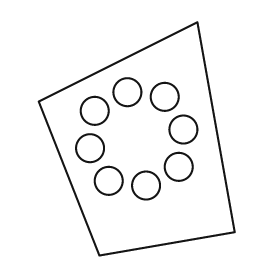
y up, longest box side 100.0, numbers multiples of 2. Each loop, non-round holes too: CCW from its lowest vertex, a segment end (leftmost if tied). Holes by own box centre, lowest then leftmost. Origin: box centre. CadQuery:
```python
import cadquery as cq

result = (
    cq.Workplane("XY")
    .moveTo(-16.0, -50.0)
    .lineTo(42.0, -40.0)
    .lineTo(26.0, 50.0)
    .lineTo(-42.0, 16.0)
    .close()
    .moveTo(4.0, -20.0)
    .circle(6.0)
    .moveTo(-12.0, -18.0)
    .circle(6.0)
    .moveTo(18.0, -12.0)
    .circle(6.0)
    .moveTo(-20.0, -4.0)
    .circle(6.0)
    .moveTo(20.0, 4.0)
    .circle(6.0)
    .moveTo(-18.0, 12.0)
    .circle(6.0)
    .moveTo(12.0, 18.0)
    .circle(6.0)
    .moveTo(-4.0, 20.0)
    .circle(6.0)
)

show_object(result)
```